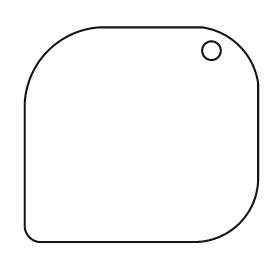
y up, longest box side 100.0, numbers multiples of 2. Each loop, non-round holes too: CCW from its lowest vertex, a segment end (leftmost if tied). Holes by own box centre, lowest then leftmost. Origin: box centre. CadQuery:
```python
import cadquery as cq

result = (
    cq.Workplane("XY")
    .moveTo(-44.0, -46.0)
    .lineTo(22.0, -46.0)
    .threePointArc((42.0, -38.0), (50.0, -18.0))
    .lineTo(50.0, 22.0)
    .threePointArc((42.0, 38.0), (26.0, 46.0))
    .lineTo(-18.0, 46.0)
    .threePointArc((-40.0, 36.0), (-50.0, 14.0))
    .lineTo(-50.0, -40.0)
    .threePointArc((-48.0, -44.0), (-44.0, -46.0))
    .close()
    .moveTo(30.0, 36.0)
    .circle(4.0)
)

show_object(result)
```